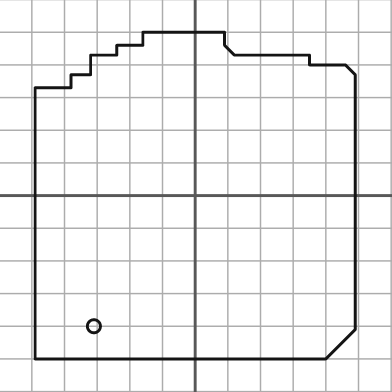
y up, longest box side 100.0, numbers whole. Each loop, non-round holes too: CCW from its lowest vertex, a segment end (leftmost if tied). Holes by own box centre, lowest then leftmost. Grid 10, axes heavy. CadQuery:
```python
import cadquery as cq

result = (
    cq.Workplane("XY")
    .moveTo(-49.0, -50.0)
    .lineTo(40.0, -50.0)
    .lineTo(49.0, -41.0)
    .lineTo(49.0, 37.0)
    .lineTo(46.0, 40.0)
    .lineTo(35.0, 40.0)
    .lineTo(35.0, 43.0)
    .lineTo(12.0, 43.0)
    .lineTo(9.0, 46.0)
    .lineTo(9.0, 50.0)
    .lineTo(-16.0, 50.0)
    .lineTo(-16.0, 46.0)
    .lineTo(-24.0, 46.0)
    .lineTo(-24.0, 43.0)
    .lineTo(-32.0, 43.0)
    .lineTo(-32.0, 37.0)
    .lineTo(-38.0, 37.0)
    .lineTo(-38.0, 33.0)
    .lineTo(-49.0, 33.0)
    .close()
    .moveTo(-31.0, -40.0)
    .circle(2.0)
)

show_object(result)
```